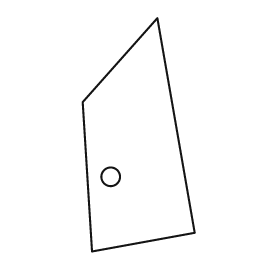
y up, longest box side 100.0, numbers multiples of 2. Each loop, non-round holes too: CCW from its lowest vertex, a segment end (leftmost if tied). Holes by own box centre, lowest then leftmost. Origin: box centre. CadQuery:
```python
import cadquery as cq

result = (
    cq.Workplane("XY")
    .moveTo(-20.0, -50.0)
    .lineTo(24.0, -42.0)
    .lineTo(8.0, 50.0)
    .lineTo(-24.0, 14.0)
    .close()
    .moveTo(-12.0, -18.0)
    .circle(4.0)
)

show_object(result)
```